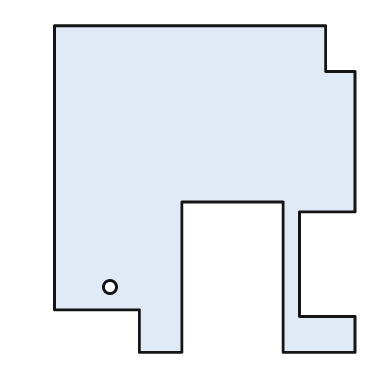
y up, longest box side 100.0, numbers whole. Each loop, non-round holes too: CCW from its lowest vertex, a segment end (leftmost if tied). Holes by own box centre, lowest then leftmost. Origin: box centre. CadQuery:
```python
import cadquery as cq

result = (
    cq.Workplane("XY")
    .moveTo(-20.0, -50.0)
    .lineTo(-7.0, -50.0)
    .lineTo(-7.0, -4.0)
    .lineTo(24.0, -4.0)
    .lineTo(24.0, -50.0)
    .lineTo(46.0, -50.0)
    .lineTo(46.0, -39.0)
    .lineTo(29.0, -39.0)
    .lineTo(29.0, -7.0)
    .lineTo(46.0, -7.0)
    .lineTo(46.0, 36.0)
    .lineTo(37.0, 36.0)
    .lineTo(37.0, 50.0)
    .lineTo(-46.0, 50.0)
    .lineTo(-46.0, -37.0)
    .lineTo(-20.0, -37.0)
    .close()
    .moveTo(-29.0, -30.0)
    .circle(2.0)
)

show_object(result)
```